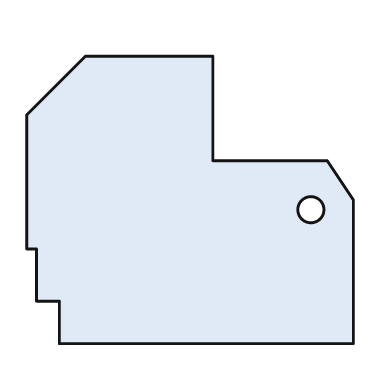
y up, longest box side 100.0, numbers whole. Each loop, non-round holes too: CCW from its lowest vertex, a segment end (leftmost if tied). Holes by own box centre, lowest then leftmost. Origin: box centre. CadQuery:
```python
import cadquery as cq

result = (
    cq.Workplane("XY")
    .moveTo(-40.0, -44.0)
    .lineTo(50.0, -44.0)
    .lineTo(50.0, 0.0)
    .lineTo(42.0, 12.0)
    .lineTo(7.0, 12.0)
    .lineTo(7.0, 44.0)
    .lineTo(-32.0, 44.0)
    .lineTo(-50.0, 26.0)
    .lineTo(-50.0, -15.0)
    .lineTo(-47.0, -15.0)
    .lineTo(-47.0, -31.0)
    .lineTo(-40.0, -31.0)
    .close()
    .moveTo(37.0, -3.0)
    .circle(4.0)
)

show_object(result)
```